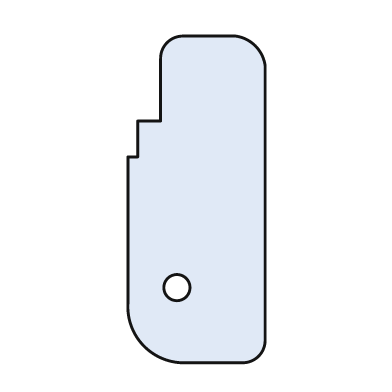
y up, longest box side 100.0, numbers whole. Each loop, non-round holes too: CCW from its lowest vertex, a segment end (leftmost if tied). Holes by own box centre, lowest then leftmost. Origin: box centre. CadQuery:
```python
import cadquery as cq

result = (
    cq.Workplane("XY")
    .moveTo(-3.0, -50.0)
    .lineTo(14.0, -50.0)
    .threePointArc((19.0, -48.0), (21.0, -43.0))
    .lineTo(21.0, 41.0)
    .threePointArc((18.0, 47.0), (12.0, 50.0))
    .lineTo(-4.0, 50.0)
    .threePointArc((-9.0, 48.0), (-11.0, 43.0))
    .lineTo(-11.0, 24.0)
    .lineTo(-18.0, 24.0)
    .lineTo(-18.0, 13.0)
    .lineTo(-21.0, 13.0)
    .lineTo(-21.0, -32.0)
    .threePointArc((-16.0, -45.0), (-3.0, -50.0))
    .close()
    .moveTo(-6.0, -27.0)
    .circle(4.0)
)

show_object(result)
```